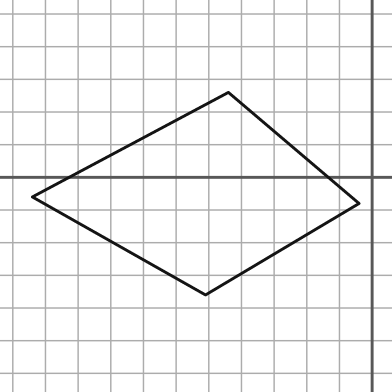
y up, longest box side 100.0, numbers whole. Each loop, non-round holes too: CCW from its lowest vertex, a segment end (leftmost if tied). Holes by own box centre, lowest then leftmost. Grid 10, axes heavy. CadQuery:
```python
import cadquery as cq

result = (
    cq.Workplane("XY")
    .moveTo(-51.0, -36.0)
    .lineTo(-4.0, -8.0)
    .lineTo(-44.0, 26.0)
    .lineTo(-104.0, -6.0)
    .close()
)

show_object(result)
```